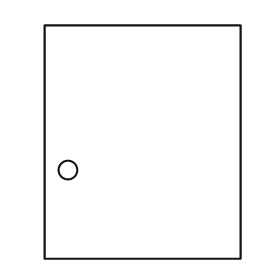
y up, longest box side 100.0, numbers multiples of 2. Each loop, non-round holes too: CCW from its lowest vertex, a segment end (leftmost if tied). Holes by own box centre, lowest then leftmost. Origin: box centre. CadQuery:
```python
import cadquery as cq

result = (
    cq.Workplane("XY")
    .moveTo(-42.0, -50.0)
    .lineTo(42.0, -50.0)
    .lineTo(42.0, 50.0)
    .lineTo(-42.0, 50.0)
    .close()
    .moveTo(-32.0, -12.0)
    .circle(4.0)
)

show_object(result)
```